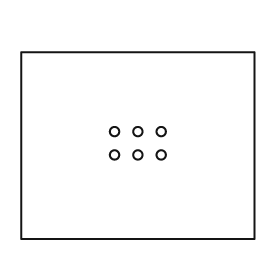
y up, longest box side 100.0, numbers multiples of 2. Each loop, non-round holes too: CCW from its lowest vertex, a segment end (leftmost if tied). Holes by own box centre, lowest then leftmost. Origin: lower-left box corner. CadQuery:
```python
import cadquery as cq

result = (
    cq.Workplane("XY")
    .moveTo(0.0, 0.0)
    .lineTo(100.0, 0.0)
    .lineTo(100.0, 80.0)
    .lineTo(0.0, 80.0)
    .close()
    .moveTo(40.0, 36.0)
    .circle(2.0)
    .moveTo(50.0, 36.0)
    .circle(2.0)
    .moveTo(60.0, 36.0)
    .circle(2.0)
    .moveTo(40.0, 46.0)
    .circle(2.0)
    .moveTo(50.0, 46.0)
    .circle(2.0)
    .moveTo(60.0, 46.0)
    .circle(2.0)
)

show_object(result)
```